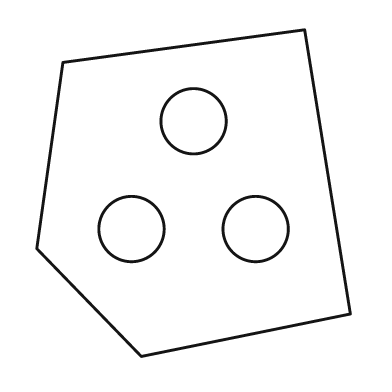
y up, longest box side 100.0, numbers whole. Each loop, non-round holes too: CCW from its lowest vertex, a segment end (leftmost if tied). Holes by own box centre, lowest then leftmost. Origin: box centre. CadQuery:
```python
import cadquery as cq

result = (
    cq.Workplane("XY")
    .moveTo(-16.0, -50.0)
    .lineTo(48.0, -37.0)
    .lineTo(34.0, 50.0)
    .lineTo(-40.0, 40.0)
    .lineTo(-48.0, -17.0)
    .close()
    .moveTo(-19.0, -11.0)
    .circle(10.0)
    .moveTo(19.0, -11.0)
    .circle(10.0)
    .moveTo(0.0, 22.0)
    .circle(10.0)
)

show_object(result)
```